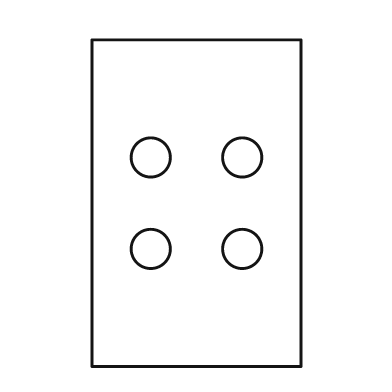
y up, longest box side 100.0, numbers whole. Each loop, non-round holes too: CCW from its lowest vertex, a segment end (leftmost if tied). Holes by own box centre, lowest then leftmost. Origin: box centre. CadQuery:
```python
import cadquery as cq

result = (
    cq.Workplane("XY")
    .moveTo(-32.0, -50.0)
    .lineTo(32.0, -50.0)
    .lineTo(32.0, 50.0)
    .lineTo(-32.0, 50.0)
    .close()
    .moveTo(-14.0, -14.0)
    .circle(6.0)
    .moveTo(14.0, -14.0)
    .circle(6.0)
    .moveTo(-14.0, 14.0)
    .circle(6.0)
    .moveTo(14.0, 14.0)
    .circle(6.0)
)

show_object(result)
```